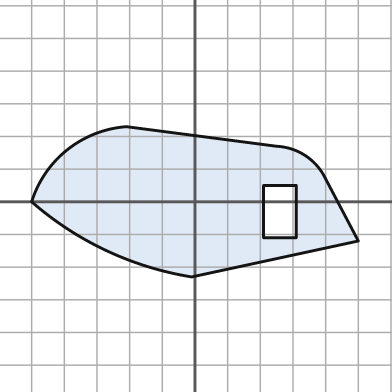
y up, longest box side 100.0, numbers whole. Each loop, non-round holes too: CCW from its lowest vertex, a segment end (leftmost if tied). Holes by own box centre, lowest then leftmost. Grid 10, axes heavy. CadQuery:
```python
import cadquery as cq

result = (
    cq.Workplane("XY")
    .moveTo(-1.0, -23.0)
    .lineTo(50.0, -12.0)
    .lineTo(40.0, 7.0)
    .threePointArc((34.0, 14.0), (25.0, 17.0))
    .lineTo(-21.0, 23.0)
    .threePointArc((-39.0, 16.0), (-50.0, 0.0))
    .threePointArc((-27.0, -15.0), (-1.0, -23.0))
    .close()
    .moveTo(21.0, -11.0)
    .lineTo(31.0, -11.0)
    .lineTo(31.0, 5.0)
    .lineTo(21.0, 5.0)
    .close()
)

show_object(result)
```